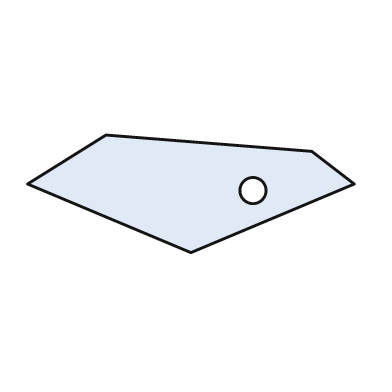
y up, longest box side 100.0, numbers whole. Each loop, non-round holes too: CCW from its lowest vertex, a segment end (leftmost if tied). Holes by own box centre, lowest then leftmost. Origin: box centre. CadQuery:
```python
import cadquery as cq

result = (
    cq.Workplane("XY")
    .moveTo(0.0, -18.0)
    .lineTo(50.0, 3.0)
    .lineTo(37.0, 13.0)
    .lineTo(-26.0, 18.0)
    .lineTo(-50.0, 3.0)
    .close()
    .moveTo(19.0, 1.0)
    .circle(4.0)
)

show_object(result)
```